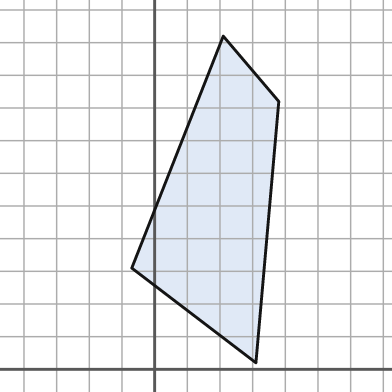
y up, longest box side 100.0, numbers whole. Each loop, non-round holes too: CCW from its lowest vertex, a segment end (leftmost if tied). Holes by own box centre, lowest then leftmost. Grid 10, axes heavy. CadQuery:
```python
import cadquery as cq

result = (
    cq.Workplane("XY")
    .moveTo(31.0, 2.0)
    .lineTo(38.0, 82.0)
    .lineTo(21.0, 102.0)
    .lineTo(-7.0, 31.0)
    .close()
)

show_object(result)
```